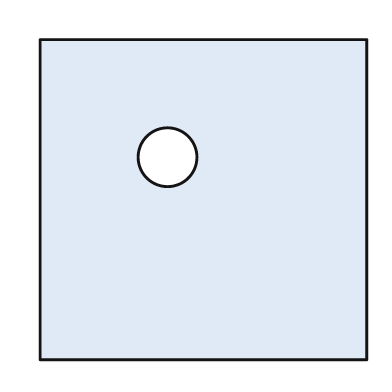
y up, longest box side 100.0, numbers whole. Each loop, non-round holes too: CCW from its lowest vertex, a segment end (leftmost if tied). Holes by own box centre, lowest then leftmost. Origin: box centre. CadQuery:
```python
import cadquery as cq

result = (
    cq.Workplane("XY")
    .moveTo(-50.0, -49.0)
    .lineTo(50.0, -49.0)
    .lineTo(50.0, 49.0)
    .lineTo(-50.0, 49.0)
    .close()
    .moveTo(-11.0, 13.0)
    .circle(9.0)
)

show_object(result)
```